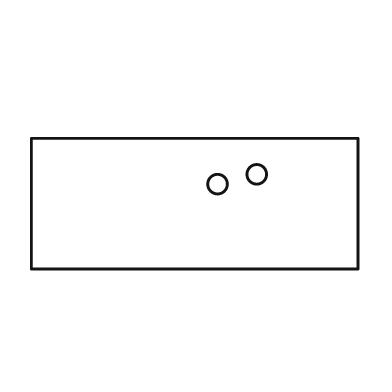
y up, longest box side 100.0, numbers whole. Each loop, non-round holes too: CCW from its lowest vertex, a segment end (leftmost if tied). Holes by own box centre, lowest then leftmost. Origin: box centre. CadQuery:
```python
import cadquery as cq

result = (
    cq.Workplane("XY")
    .moveTo(-50.0, -20.0)
    .lineTo(50.0, -20.0)
    .lineTo(50.0, 20.0)
    .lineTo(-50.0, 20.0)
    .close()
    .moveTo(7.0, 6.0)
    .circle(3.0)
    .moveTo(19.0, 9.0)
    .circle(3.0)
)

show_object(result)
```